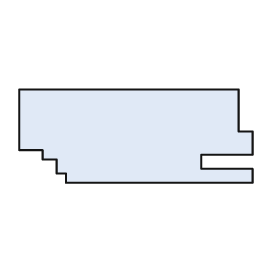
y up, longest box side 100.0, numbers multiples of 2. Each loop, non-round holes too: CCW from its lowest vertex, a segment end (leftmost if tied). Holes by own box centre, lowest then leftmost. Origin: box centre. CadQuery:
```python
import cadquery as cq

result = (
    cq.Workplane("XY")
    .moveTo(-30.0, -20.0)
    .lineTo(50.0, -20.0)
    .lineTo(50.0, -14.0)
    .lineTo(28.0, -14.0)
    .lineTo(28.0, -8.0)
    .lineTo(50.0, -8.0)
    .lineTo(50.0, 2.0)
    .lineTo(44.0, 2.0)
    .lineTo(44.0, 20.0)
    .lineTo(-50.0, 20.0)
    .lineTo(-50.0, -6.0)
    .lineTo(-40.0, -6.0)
    .lineTo(-40.0, -10.0)
    .lineTo(-34.0, -10.0)
    .lineTo(-34.0, -16.0)
    .lineTo(-30.0, -16.0)
    .close()
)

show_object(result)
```